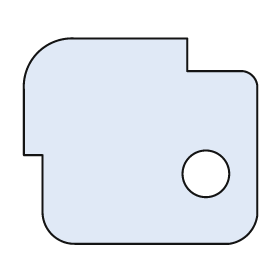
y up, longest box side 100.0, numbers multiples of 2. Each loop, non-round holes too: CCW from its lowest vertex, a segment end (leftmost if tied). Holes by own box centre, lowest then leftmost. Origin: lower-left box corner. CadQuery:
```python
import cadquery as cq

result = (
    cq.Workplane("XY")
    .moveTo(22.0, 0.0)
    .lineTo(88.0, 0.0)
    .threePointArc((96.0, 4.0), (100.0, 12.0))
    .lineTo(100.0, 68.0)
    .threePointArc((98.0, 72.0), (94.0, 74.0))
    .lineTo(70.0, 74.0)
    .lineTo(70.0, 88.0)
    .lineTo(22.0, 88.0)
    .threePointArc((6.0, 82.0), (0.0, 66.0))
    .lineTo(0.0, 38.0)
    .lineTo(8.0, 38.0)
    .lineTo(8.0, 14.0)
    .threePointArc((12.0, 4.0), (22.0, 0.0))
    .close()
    .moveTo(78.0, 30.0)
    .circle(10.0)
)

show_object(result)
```